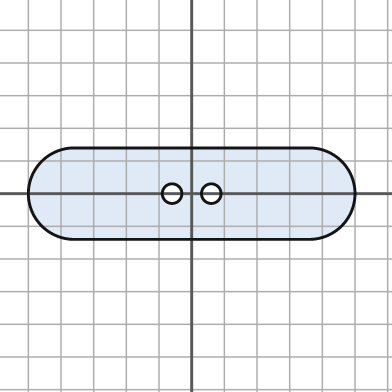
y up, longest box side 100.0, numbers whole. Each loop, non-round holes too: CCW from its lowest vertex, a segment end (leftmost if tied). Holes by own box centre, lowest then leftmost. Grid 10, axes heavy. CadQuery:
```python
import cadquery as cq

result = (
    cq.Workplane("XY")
    .moveTo(-36.0, -14.0)
    .lineTo(36.0, -14.0)
    .threePointArc((50.0, 0.0), (36.0, 14.0))
    .lineTo(-36.0, 14.0)
    .threePointArc((-50.0, 0.0), (-36.0, -14.0))
    .close()
    .moveTo(-6.0, 0.0)
    .circle(3.0)
    .moveTo(6.0, 0.0)
    .circle(3.0)
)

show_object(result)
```